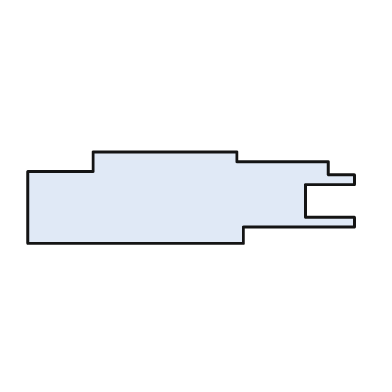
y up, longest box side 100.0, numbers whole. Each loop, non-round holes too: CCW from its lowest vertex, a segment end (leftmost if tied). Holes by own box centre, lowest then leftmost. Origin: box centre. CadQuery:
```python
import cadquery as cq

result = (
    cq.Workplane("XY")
    .moveTo(-50.0, -14.0)
    .lineTo(16.0, -14.0)
    .lineTo(16.0, -9.0)
    .lineTo(50.0, -9.0)
    .lineTo(50.0, -6.0)
    .lineTo(35.0, -6.0)
    .lineTo(35.0, 4.0)
    .lineTo(50.0, 4.0)
    .lineTo(50.0, 7.0)
    .lineTo(42.0, 7.0)
    .lineTo(42.0, 11.0)
    .lineTo(14.0, 11.0)
    .lineTo(14.0, 14.0)
    .lineTo(-30.0, 14.0)
    .lineTo(-30.0, 8.0)
    .lineTo(-50.0, 8.0)
    .close()
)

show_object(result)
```